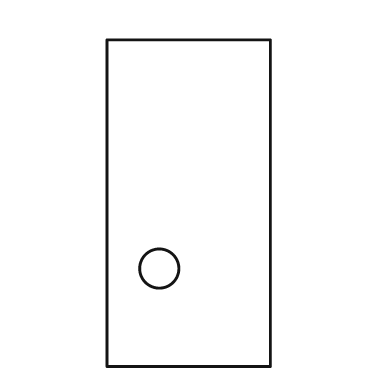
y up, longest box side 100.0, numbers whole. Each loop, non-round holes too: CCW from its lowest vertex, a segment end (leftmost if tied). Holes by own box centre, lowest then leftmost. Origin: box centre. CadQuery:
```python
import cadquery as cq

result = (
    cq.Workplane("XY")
    .moveTo(-25.0, -50.0)
    .lineTo(25.0, -50.0)
    .lineTo(25.0, 50.0)
    .lineTo(-25.0, 50.0)
    .close()
    .moveTo(-9.0, -20.0)
    .circle(6.0)
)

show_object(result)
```